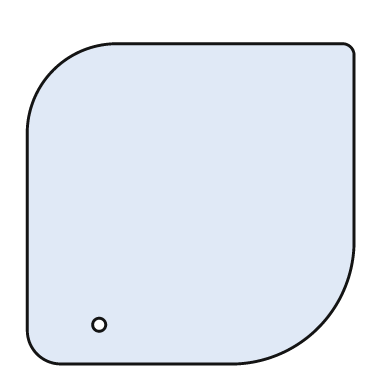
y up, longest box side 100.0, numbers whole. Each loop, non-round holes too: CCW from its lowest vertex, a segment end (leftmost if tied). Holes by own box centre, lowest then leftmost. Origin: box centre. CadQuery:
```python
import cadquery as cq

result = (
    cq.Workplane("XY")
    .moveTo(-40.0, -49.0)
    .lineTo(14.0, -49.0)
    .threePointArc((39.0, -38.0), (50.0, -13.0))
    .lineTo(50.0, 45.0)
    .threePointArc((49.0, 48.0), (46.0, 49.0))
    .lineTo(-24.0, 49.0)
    .threePointArc((-42.0, 41.0), (-50.0, 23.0))
    .lineTo(-50.0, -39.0)
    .threePointArc((-47.0, -46.0), (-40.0, -49.0))
    .close()
    .moveTo(-28.0, -37.0)
    .circle(2.0)
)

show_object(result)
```